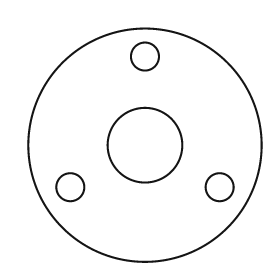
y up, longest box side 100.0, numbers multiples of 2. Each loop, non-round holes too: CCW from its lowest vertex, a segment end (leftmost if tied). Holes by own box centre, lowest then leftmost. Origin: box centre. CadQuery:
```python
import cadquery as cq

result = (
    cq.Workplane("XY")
    .moveTo(0.0, 0.0)
    .circle(50.0)
    .moveTo(-32.0, -18.0)
    .circle(6.0)
    .moveTo(32.0, -18.0)
    .circle(6.0)
    .moveTo(0.0, 0.0)
    .circle(16.0)
    .moveTo(0.0, 38.0)
    .circle(6.0)
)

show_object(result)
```